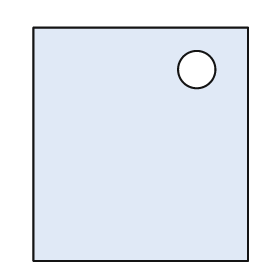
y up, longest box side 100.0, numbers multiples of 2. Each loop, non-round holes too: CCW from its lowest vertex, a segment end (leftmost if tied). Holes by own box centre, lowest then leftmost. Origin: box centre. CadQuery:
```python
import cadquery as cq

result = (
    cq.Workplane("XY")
    .moveTo(-46.0, -50.0)
    .lineTo(46.0, -50.0)
    .lineTo(46.0, 50.0)
    .lineTo(-46.0, 50.0)
    .close()
    .moveTo(24.0, 32.0)
    .circle(8.0)
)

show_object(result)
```